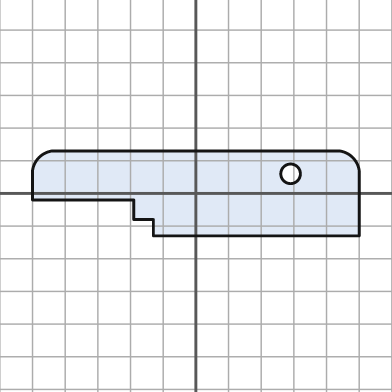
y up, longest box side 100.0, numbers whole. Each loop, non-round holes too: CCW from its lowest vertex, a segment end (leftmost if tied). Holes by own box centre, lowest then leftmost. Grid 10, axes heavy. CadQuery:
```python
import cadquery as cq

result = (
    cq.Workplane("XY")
    .moveTo(-13.0, -13.0)
    .lineTo(50.0, -13.0)
    .lineTo(50.0, 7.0)
    .threePointArc((48.0, 11.0), (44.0, 13.0))
    .lineTo(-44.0, 13.0)
    .threePointArc((-48.0, 11.0), (-50.0, 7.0))
    .lineTo(-50.0, -2.0)
    .lineTo(-19.0, -2.0)
    .lineTo(-19.0, -8.0)
    .lineTo(-13.0, -8.0)
    .close()
    .moveTo(29.0, 6.0)
    .circle(3.0)
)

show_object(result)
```